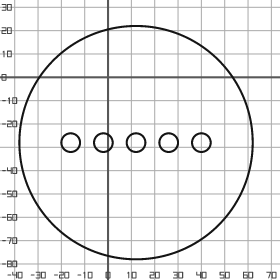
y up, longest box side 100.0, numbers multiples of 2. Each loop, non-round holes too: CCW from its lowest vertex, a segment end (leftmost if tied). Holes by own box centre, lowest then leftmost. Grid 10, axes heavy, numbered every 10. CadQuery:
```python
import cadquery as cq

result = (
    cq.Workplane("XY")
    .moveTo(12.0, -28.0)
    .circle(50.0)
    .moveTo(-16.0, -28.0)
    .circle(4.0)
    .moveTo(-2.0, -28.0)
    .circle(4.0)
    .moveTo(12.0, -28.0)
    .circle(4.0)
    .moveTo(26.0, -28.0)
    .circle(4.0)
    .moveTo(40.0, -28.0)
    .circle(4.0)
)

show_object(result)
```